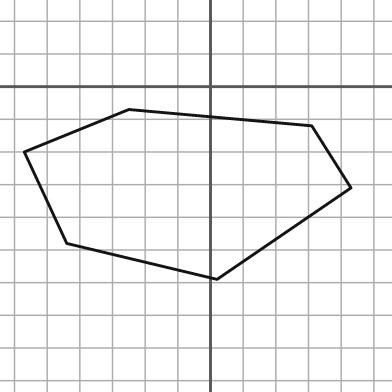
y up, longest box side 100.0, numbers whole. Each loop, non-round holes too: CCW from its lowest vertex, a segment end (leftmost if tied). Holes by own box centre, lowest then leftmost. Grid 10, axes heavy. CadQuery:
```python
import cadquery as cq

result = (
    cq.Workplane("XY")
    .moveTo(2.0, -59.0)
    .lineTo(43.0, -31.0)
    .lineTo(31.0, -12.0)
    .lineTo(-25.0, -7.0)
    .lineTo(-57.0, -20.0)
    .lineTo(-44.0, -48.0)
    .close()
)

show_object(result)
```